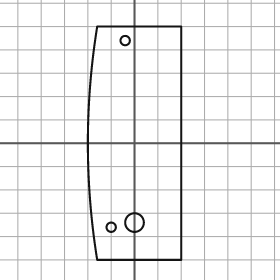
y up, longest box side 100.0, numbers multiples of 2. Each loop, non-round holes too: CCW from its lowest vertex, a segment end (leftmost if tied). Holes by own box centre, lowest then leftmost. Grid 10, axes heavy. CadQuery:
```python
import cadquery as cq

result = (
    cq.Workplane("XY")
    .moveTo(-16.0, -50.0)
    .lineTo(20.0, -50.0)
    .lineTo(20.0, 50.0)
    .lineTo(-16.0, 50.0)
    .threePointArc((-20.0, 0.0), (-16.0, -50.0))
    .close()
    .moveTo(-10.0, -36.0)
    .circle(2.0)
    .moveTo(0.0, -34.0)
    .circle(4.0)
    .moveTo(-4.0, 44.0)
    .circle(2.0)
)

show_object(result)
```